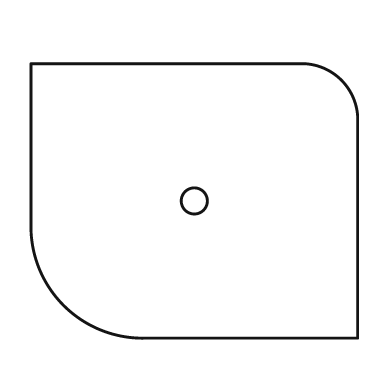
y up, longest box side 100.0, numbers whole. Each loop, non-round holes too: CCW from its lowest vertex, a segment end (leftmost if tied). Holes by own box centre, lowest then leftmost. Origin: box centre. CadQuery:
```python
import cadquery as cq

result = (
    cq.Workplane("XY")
    .moveTo(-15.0, -42.0)
    .lineTo(50.0, -42.0)
    .lineTo(50.0, 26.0)
    .threePointArc((45.0, 37.0), (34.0, 42.0))
    .lineTo(-50.0, 42.0)
    .lineTo(-50.0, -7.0)
    .threePointArc((-40.0, -32.0), (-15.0, -42.0))
    .close()
    .moveTo(0.0, 0.0)
    .circle(4.0)
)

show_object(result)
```